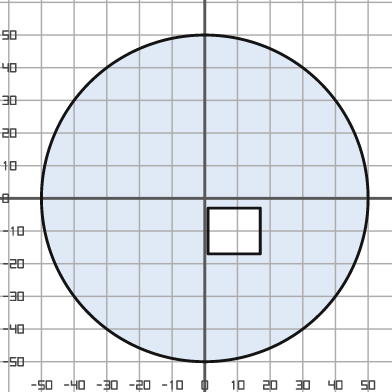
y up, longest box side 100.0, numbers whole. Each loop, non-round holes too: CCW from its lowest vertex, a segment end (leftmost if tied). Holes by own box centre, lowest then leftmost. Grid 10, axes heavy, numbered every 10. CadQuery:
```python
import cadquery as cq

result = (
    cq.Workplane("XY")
    .moveTo(0.0, 0.0)
    .circle(50.0)
    .moveTo(1.0, -17.0)
    .lineTo(17.0, -17.0)
    .lineTo(17.0, -3.0)
    .lineTo(1.0, -3.0)
    .close()
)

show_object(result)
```